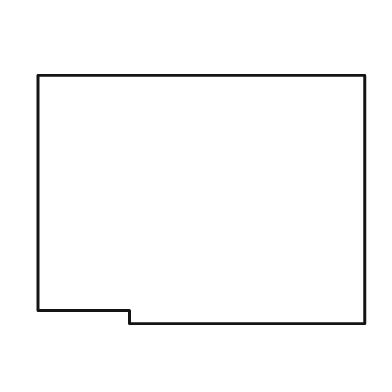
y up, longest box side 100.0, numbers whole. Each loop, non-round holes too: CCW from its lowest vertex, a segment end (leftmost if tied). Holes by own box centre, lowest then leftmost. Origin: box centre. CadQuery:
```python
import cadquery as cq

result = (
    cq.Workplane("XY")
    .moveTo(-22.0, -38.0)
    .lineTo(50.0, -38.0)
    .lineTo(50.0, 38.0)
    .lineTo(-50.0, 38.0)
    .lineTo(-50.0, -34.0)
    .lineTo(-22.0, -34.0)
    .close()
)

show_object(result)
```